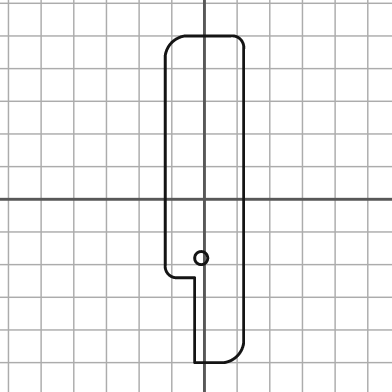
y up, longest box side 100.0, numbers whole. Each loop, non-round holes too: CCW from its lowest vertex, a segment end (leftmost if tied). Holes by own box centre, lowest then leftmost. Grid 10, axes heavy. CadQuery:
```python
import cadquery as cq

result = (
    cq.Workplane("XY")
    .moveTo(-3.0, -50.0)
    .lineTo(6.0, -50.0)
    .threePointArc((10.0, -48.0), (12.0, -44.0))
    .lineTo(12.0, 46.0)
    .threePointArc((11.0, 49.0), (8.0, 50.0))
    .lineTo(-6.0, 50.0)
    .threePointArc((-10.0, 48.0), (-12.0, 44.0))
    .lineTo(-12.0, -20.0)
    .threePointArc((-11.0, -23.0), (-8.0, -24.0))
    .lineTo(-3.0, -24.0)
    .close()
    .moveTo(-1.0, -18.0)
    .circle(2.0)
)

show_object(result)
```